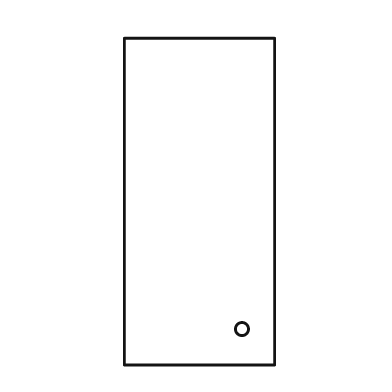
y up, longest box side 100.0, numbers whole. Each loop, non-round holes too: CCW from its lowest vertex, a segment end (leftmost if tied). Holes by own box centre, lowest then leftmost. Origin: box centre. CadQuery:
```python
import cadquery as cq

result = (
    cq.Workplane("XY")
    .moveTo(-23.0, -50.0)
    .lineTo(23.0, -50.0)
    .lineTo(23.0, 50.0)
    .lineTo(-23.0, 50.0)
    .close()
    .moveTo(13.0, -39.0)
    .circle(2.0)
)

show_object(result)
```